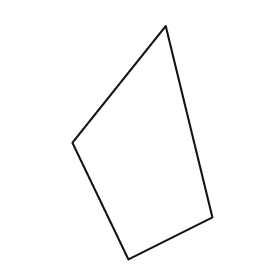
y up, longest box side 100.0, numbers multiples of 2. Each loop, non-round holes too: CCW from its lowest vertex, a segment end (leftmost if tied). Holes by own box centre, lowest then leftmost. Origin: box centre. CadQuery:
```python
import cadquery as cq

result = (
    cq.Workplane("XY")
    .moveTo(-6.0, -50.0)
    .lineTo(30.0, -32.0)
    .lineTo(10.0, 50.0)
    .lineTo(-30.0, 0.0)
    .close()
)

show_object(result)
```